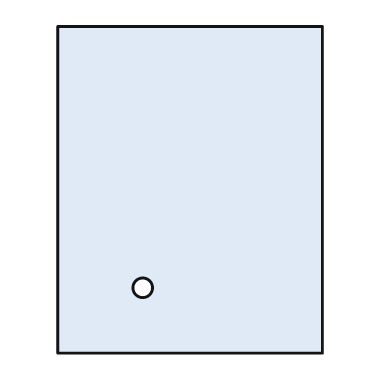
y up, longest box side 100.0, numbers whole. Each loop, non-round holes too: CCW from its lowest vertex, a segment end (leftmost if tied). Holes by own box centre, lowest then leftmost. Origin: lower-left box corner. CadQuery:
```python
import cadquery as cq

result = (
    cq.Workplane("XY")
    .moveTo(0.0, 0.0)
    .lineTo(81.0, 0.0)
    .lineTo(81.0, 100.0)
    .lineTo(0.0, 100.0)
    .close()
    .moveTo(26.0, 20.0)
    .circle(3.0)
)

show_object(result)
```